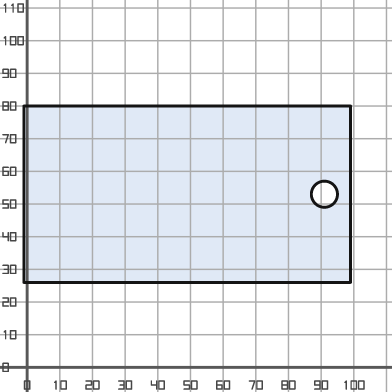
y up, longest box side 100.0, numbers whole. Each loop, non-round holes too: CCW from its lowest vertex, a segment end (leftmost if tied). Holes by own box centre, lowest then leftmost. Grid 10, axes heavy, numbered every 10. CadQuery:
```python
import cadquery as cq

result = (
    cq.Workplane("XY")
    .moveTo(-1.0, 26.0)
    .lineTo(99.0, 26.0)
    .lineTo(99.0, 80.0)
    .lineTo(-1.0, 80.0)
    .close()
    .moveTo(91.0, 53.0)
    .circle(4.0)
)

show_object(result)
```